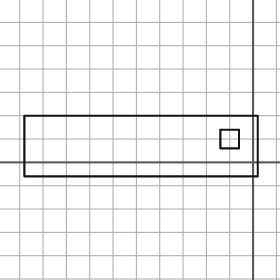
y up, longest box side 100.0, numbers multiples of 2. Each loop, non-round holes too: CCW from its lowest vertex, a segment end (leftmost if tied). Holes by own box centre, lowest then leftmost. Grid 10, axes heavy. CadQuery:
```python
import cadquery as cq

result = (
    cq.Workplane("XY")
    .moveTo(-98.0, -6.0)
    .lineTo(2.0, -6.0)
    .lineTo(2.0, 20.0)
    .lineTo(-98.0, 20.0)
    .close()
    .moveTo(-14.0, 6.0)
    .lineTo(-6.0, 6.0)
    .lineTo(-6.0, 14.0)
    .lineTo(-14.0, 14.0)
    .close()
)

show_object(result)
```